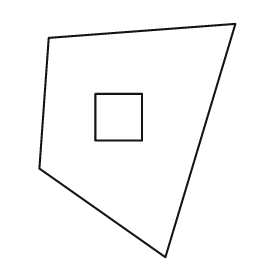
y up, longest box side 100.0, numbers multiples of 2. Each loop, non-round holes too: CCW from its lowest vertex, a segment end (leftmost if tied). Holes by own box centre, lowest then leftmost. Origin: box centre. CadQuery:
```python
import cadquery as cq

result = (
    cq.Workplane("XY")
    .moveTo(12.0, -50.0)
    .lineTo(42.0, 50.0)
    .lineTo(-38.0, 44.0)
    .lineTo(-42.0, -12.0)
    .close()
    .moveTo(-18.0, 0.0)
    .lineTo(2.0, 0.0)
    .lineTo(2.0, 20.0)
    .lineTo(-18.0, 20.0)
    .close()
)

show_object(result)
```